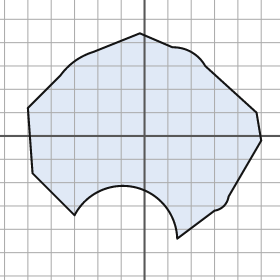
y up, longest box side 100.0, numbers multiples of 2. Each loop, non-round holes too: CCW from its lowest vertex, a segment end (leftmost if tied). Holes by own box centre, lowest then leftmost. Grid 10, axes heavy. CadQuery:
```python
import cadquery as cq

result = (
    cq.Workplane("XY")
    .moveTo(14.0, -44.0)
    .lineTo(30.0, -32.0)
    .threePointArc((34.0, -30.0), (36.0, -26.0))
    .lineTo(50.0, -2.0)
    .lineTo(48.0, 10.0)
    .lineTo(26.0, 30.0)
    .threePointArc((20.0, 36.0), (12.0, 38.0))
    .lineTo(-2.0, 44.0)
    .lineTo(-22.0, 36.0)
    .threePointArc((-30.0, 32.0), (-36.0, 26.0))
    .lineTo(-50.0, 12.0)
    .lineTo(-48.0, -16.0)
    .lineTo(-30.0, -34.0)
    .threePointArc((-4.0, -22.0), (14.0, -44.0))
    .close()
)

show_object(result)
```